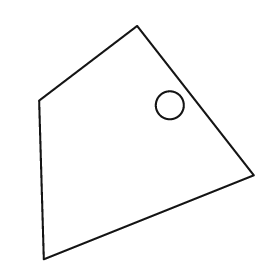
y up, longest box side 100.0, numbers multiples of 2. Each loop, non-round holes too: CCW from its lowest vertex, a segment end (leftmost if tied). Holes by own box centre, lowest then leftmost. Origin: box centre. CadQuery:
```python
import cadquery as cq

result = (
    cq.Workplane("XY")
    .moveTo(-44.0, -50.0)
    .lineTo(46.0, -14.0)
    .lineTo(-4.0, 50.0)
    .lineTo(-46.0, 18.0)
    .close()
    .moveTo(10.0, 16.0)
    .circle(6.0)
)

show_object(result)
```